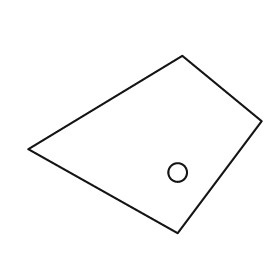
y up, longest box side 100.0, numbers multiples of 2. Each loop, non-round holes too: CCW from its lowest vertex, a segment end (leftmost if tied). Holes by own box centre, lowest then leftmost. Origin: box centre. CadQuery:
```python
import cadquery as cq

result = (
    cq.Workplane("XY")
    .moveTo(14.0, -38.0)
    .lineTo(50.0, 10.0)
    .lineTo(16.0, 38.0)
    .lineTo(-50.0, -2.0)
    .close()
    .moveTo(14.0, -12.0)
    .circle(4.0)
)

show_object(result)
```